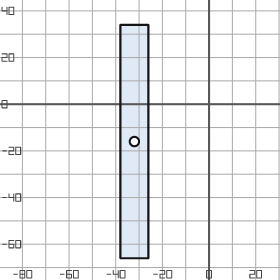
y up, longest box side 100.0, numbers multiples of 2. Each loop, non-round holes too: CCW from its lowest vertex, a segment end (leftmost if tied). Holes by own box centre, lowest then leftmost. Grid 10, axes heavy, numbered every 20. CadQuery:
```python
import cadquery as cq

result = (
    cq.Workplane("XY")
    .moveTo(-38.0, -66.0)
    .lineTo(-26.0, -66.0)
    .lineTo(-26.0, 34.0)
    .lineTo(-38.0, 34.0)
    .close()
    .moveTo(-32.0, -16.0)
    .circle(2.0)
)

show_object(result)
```